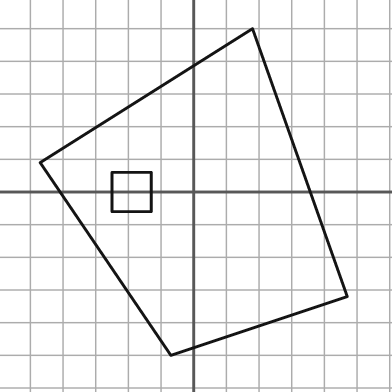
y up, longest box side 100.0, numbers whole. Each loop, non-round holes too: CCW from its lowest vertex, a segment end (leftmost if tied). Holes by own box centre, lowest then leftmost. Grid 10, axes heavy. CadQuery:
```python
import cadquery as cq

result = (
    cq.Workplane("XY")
    .moveTo(-7.0, -50.0)
    .lineTo(47.0, -32.0)
    .lineTo(18.0, 50.0)
    .lineTo(-47.0, 9.0)
    .close()
    .moveTo(-25.0, -6.0)
    .lineTo(-13.0, -6.0)
    .lineTo(-13.0, 6.0)
    .lineTo(-25.0, 6.0)
    .close()
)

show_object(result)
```